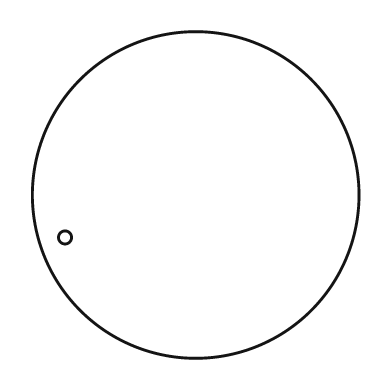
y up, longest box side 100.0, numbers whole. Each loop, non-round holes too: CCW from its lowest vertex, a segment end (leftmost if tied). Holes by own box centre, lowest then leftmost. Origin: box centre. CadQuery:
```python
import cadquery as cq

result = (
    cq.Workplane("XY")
    .moveTo(0.0, 0.0)
    .circle(50.0)
    .moveTo(-40.0, -13.0)
    .circle(2.0)
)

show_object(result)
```